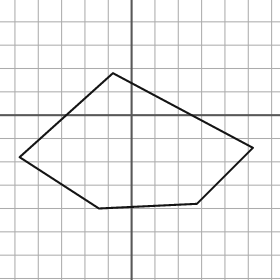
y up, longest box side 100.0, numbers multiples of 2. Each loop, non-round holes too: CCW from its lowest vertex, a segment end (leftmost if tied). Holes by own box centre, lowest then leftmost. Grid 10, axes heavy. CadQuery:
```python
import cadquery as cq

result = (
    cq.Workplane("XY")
    .moveTo(-14.0, -40.0)
    .lineTo(28.0, -38.0)
    .lineTo(52.0, -14.0)
    .lineTo(-8.0, 18.0)
    .lineTo(-48.0, -18.0)
    .close()
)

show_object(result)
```